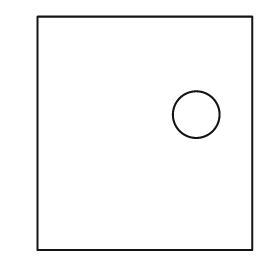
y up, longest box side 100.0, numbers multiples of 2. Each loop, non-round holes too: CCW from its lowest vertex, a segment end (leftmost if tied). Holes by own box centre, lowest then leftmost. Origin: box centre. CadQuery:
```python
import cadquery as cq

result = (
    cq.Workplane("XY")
    .moveTo(-46.0, -50.0)
    .lineTo(46.0, -50.0)
    .lineTo(46.0, 50.0)
    .lineTo(-46.0, 50.0)
    .close()
    .moveTo(22.0, 8.0)
    .circle(10.0)
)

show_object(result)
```